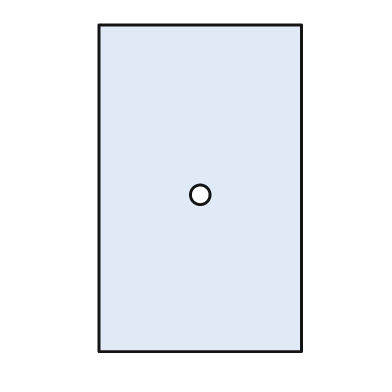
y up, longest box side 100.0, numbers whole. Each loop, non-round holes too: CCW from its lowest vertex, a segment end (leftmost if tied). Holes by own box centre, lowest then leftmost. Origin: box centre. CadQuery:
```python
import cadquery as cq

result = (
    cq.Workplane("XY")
    .moveTo(-31.0, -50.0)
    .lineTo(31.0, -50.0)
    .lineTo(31.0, 50.0)
    .lineTo(-31.0, 50.0)
    .close()
    .moveTo(0.0, -2.0)
    .circle(3.0)
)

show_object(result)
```